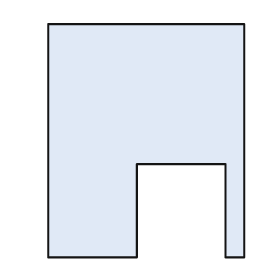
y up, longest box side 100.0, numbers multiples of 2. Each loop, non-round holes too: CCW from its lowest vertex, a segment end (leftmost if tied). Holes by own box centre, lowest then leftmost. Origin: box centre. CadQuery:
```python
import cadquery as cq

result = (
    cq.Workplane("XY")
    .moveTo(-42.0, -50.0)
    .lineTo(-4.0, -50.0)
    .lineTo(-4.0, -10.0)
    .lineTo(34.0, -10.0)
    .lineTo(34.0, -50.0)
    .lineTo(42.0, -50.0)
    .lineTo(42.0, 50.0)
    .lineTo(-42.0, 50.0)
    .close()
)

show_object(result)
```